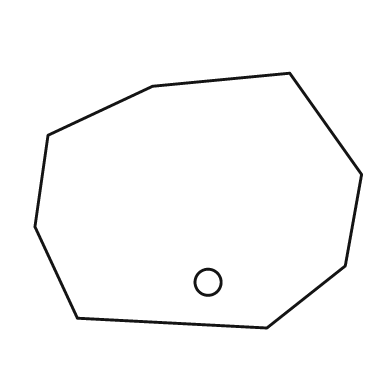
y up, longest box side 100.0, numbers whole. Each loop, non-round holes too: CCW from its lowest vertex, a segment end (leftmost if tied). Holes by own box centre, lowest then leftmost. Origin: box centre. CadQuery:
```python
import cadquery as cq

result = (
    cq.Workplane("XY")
    .moveTo(21.0, -39.0)
    .lineTo(45.0, -20.0)
    .lineTo(50.0, 8.0)
    .lineTo(28.0, 39.0)
    .lineTo(-14.0, 35.0)
    .lineTo(-46.0, 20.0)
    .lineTo(-50.0, -8.0)
    .lineTo(-37.0, -36.0)
    .close()
    .moveTo(3.0, -25.0)
    .circle(4.0)
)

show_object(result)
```